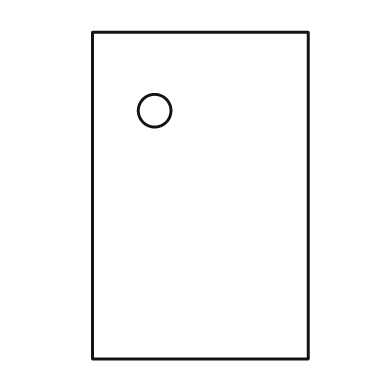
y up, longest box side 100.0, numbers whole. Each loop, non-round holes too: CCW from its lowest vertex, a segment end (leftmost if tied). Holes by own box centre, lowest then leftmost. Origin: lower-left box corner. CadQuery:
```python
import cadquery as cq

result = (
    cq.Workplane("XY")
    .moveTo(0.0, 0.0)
    .lineTo(66.0, 0.0)
    .lineTo(66.0, 100.0)
    .lineTo(0.0, 100.0)
    .close()
    .moveTo(19.0, 76.0)
    .circle(5.0)
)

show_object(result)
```